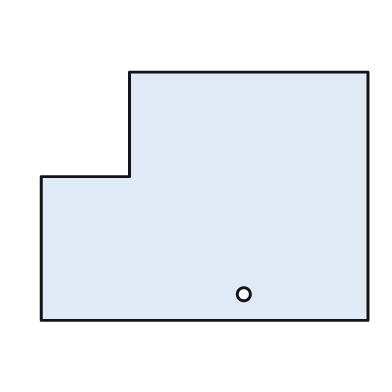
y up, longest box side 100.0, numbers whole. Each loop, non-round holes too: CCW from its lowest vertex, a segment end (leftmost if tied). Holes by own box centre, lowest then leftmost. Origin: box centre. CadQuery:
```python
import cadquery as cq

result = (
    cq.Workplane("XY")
    .moveTo(-50.0, -38.0)
    .lineTo(50.0, -38.0)
    .lineTo(50.0, 38.0)
    .lineTo(-23.0, 38.0)
    .lineTo(-23.0, 6.0)
    .lineTo(-50.0, 6.0)
    .close()
    .moveTo(12.0, -30.0)
    .circle(2.0)
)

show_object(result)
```